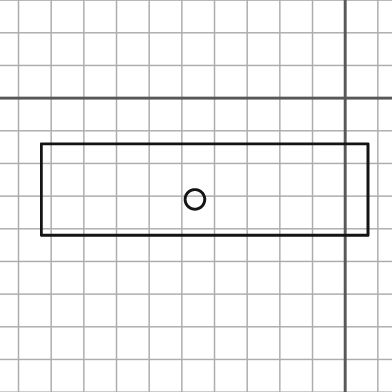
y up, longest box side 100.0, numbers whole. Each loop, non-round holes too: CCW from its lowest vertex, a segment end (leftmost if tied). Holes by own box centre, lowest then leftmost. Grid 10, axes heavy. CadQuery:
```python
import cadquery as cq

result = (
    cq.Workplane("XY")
    .moveTo(-93.0, -42.0)
    .lineTo(7.0, -42.0)
    .lineTo(7.0, -14.0)
    .lineTo(-93.0, -14.0)
    .close()
    .moveTo(-46.0, -31.0)
    .circle(3.0)
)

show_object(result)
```